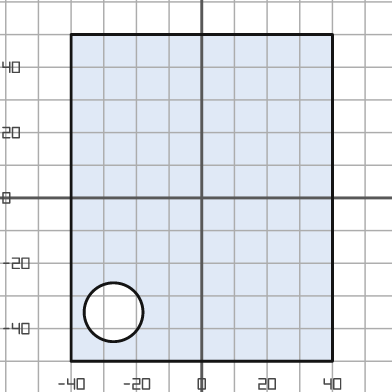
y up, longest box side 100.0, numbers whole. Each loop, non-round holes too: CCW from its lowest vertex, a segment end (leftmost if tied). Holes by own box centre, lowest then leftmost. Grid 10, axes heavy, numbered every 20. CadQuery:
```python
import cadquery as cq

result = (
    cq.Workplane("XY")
    .moveTo(-40.0, -50.0)
    .lineTo(40.0, -50.0)
    .lineTo(40.0, 50.0)
    .lineTo(-40.0, 50.0)
    .close()
    .moveTo(-27.0, -35.0)
    .circle(9.0)
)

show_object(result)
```